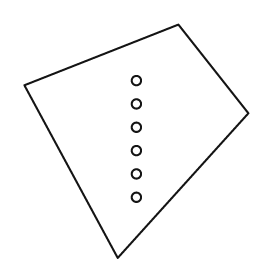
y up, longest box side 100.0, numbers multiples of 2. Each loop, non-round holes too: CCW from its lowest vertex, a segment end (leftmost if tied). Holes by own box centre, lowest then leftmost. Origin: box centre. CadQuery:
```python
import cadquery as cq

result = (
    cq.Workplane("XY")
    .moveTo(-8.0, -50.0)
    .lineTo(48.0, 12.0)
    .lineTo(18.0, 50.0)
    .lineTo(-48.0, 24.0)
    .close()
    .moveTo(0.0, -24.0)
    .circle(2.0)
    .moveTo(0.0, -14.0)
    .circle(2.0)
    .moveTo(0.0, -4.0)
    .circle(2.0)
    .moveTo(0.0, 6.0)
    .circle(2.0)
    .moveTo(0.0, 16.0)
    .circle(2.0)
    .moveTo(0.0, 26.0)
    .circle(2.0)
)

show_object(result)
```